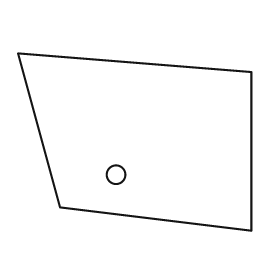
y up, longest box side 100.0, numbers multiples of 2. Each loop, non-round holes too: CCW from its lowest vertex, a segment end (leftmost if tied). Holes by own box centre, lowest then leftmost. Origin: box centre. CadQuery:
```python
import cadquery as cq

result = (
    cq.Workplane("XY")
    .moveTo(50.0, -38.0)
    .lineTo(50.0, 30.0)
    .lineTo(-50.0, 38.0)
    .lineTo(-32.0, -28.0)
    .close()
    .moveTo(-8.0, -14.0)
    .circle(4.0)
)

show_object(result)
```